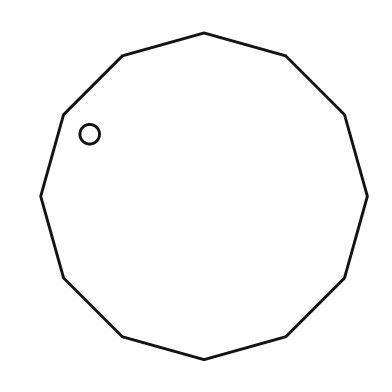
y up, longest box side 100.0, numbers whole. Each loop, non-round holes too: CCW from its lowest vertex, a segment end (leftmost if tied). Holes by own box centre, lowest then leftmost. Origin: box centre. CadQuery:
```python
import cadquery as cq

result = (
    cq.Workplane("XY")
    .moveTo(0.0, -50.0)
    .lineTo(25.0, -43.0)
    .lineTo(43.0, -25.0)
    .lineTo(50.0, 0.0)
    .lineTo(43.0, 25.0)
    .lineTo(25.0, 43.0)
    .lineTo(0.0, 50.0)
    .lineTo(-25.0, 43.0)
    .lineTo(-43.0, 25.0)
    .lineTo(-50.0, 0.0)
    .lineTo(-43.0, -25.0)
    .lineTo(-25.0, -43.0)
    .close()
    .moveTo(-35.0, 19.0)
    .circle(3.0)
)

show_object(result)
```